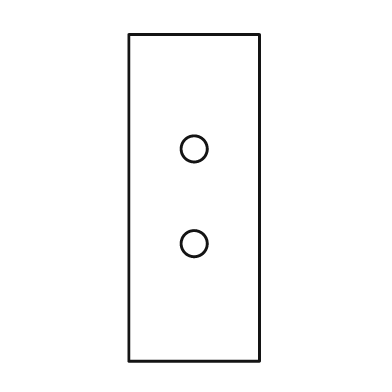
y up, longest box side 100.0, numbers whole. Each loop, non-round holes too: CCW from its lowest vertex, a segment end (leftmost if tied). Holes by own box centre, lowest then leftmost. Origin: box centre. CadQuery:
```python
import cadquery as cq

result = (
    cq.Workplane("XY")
    .moveTo(-20.0, -50.0)
    .lineTo(20.0, -50.0)
    .lineTo(20.0, 50.0)
    .lineTo(-20.0, 50.0)
    .close()
    .moveTo(0.0, -14.0)
    .circle(4.0)
    .moveTo(0.0, 15.0)
    .circle(4.0)
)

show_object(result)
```